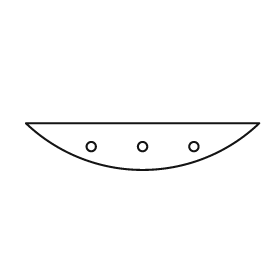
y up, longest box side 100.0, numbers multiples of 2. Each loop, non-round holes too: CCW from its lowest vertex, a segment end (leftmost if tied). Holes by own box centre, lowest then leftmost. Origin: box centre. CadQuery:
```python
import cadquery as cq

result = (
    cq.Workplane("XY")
    .moveTo(-50.0, 10.0)
    .threePointArc((0.0, -10.0), (50.0, 10.0))
    .close()
    .moveTo(-22.0, 0.0)
    .circle(2.0)
    .moveTo(0.0, 0.0)
    .circle(2.0)
    .moveTo(22.0, 0.0)
    .circle(2.0)
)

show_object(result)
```